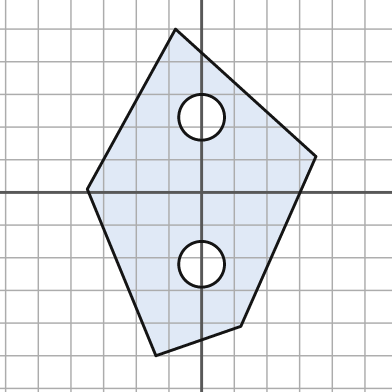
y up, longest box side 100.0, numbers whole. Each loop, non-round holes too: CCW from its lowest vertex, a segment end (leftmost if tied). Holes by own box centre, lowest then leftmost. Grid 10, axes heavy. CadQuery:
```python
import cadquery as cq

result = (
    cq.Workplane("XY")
    .moveTo(-14.0, -50.0)
    .lineTo(12.0, -41.0)
    .lineTo(35.0, 11.0)
    .lineTo(-8.0, 50.0)
    .lineTo(-35.0, 1.0)
    .close()
    .moveTo(0.0, -22.0)
    .circle(7.0)
    .moveTo(0.0, 23.0)
    .circle(7.0)
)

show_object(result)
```